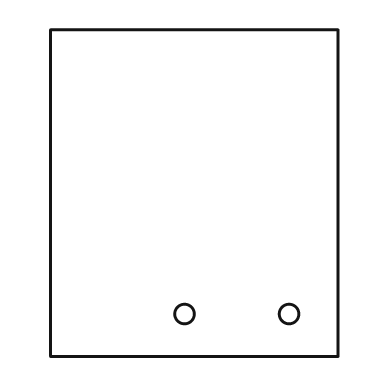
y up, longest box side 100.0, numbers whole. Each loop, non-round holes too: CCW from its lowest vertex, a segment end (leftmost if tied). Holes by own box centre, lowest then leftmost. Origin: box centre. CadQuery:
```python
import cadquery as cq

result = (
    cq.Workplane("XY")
    .moveTo(-44.0, -50.0)
    .lineTo(44.0, -50.0)
    .lineTo(44.0, 50.0)
    .lineTo(-44.0, 50.0)
    .close()
    .moveTo(-3.0, -37.0)
    .circle(3.0)
    .moveTo(29.0, -37.0)
    .circle(3.0)
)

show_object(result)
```